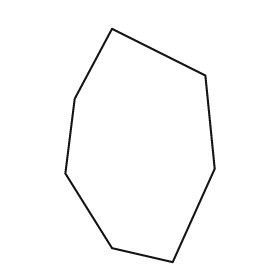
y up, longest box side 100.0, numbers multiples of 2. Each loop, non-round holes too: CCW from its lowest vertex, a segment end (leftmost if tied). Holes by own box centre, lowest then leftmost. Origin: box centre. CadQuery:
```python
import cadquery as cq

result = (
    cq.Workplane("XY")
    .moveTo(14.0, -50.0)
    .lineTo(32.0, -10.0)
    .lineTo(28.0, 30.0)
    .lineTo(-12.0, 50.0)
    .lineTo(-28.0, 20.0)
    .lineTo(-32.0, -12.0)
    .lineTo(-12.0, -44.0)
    .close()
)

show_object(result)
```